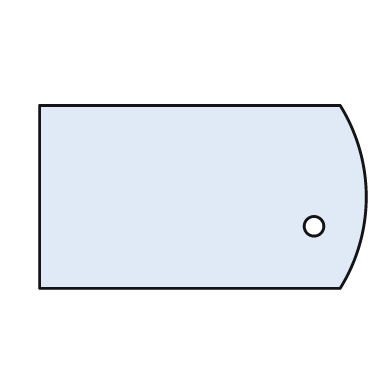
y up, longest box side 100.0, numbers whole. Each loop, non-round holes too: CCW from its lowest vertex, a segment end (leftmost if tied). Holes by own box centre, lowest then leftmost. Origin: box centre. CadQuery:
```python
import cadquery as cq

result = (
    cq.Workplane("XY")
    .moveTo(-50.0, -28.0)
    .lineTo(42.0, -28.0)
    .threePointArc((50.0, 0.0), (42.0, 28.0))
    .lineTo(-50.0, 28.0)
    .close()
    .moveTo(34.0, -9.0)
    .circle(3.0)
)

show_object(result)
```